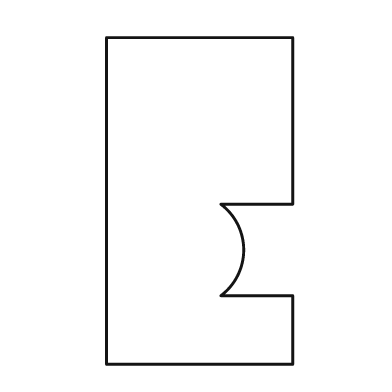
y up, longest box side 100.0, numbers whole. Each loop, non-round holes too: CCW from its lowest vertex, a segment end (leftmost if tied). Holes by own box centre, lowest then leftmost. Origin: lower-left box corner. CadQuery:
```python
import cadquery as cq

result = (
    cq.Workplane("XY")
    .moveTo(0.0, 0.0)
    .lineTo(57.0, 0.0)
    .lineTo(57.0, 21.0)
    .lineTo(35.0, 21.0)
    .threePointArc((42.0, 35.0), (35.0, 49.0))
    .lineTo(57.0, 49.0)
    .lineTo(57.0, 100.0)
    .lineTo(0.0, 100.0)
    .close()
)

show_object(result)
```